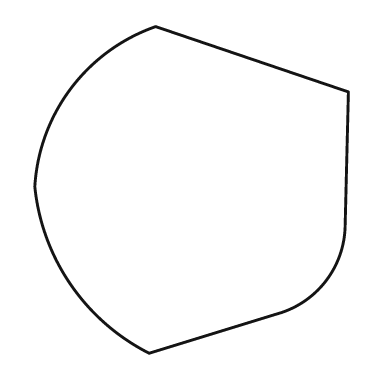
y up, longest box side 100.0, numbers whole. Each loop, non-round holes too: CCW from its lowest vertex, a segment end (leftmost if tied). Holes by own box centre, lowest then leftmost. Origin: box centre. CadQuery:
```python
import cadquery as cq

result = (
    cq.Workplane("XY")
    .moveTo(-13.0, -50.0)
    .lineTo(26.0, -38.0)
    .threePointArc((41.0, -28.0), (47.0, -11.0))
    .lineTo(48.0, 30.0)
    .lineTo(-11.0, 50.0)
    .threePointArc((-37.0, 31.0), (-48.0, 1.0))
    .threePointArc((-37.0, -29.0), (-13.0, -50.0))
    .close()
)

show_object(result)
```